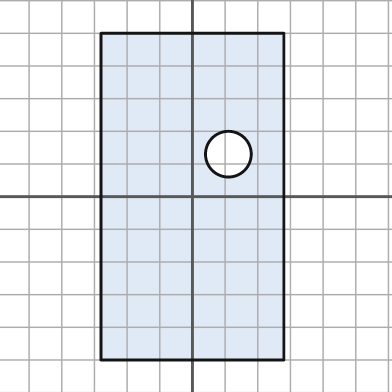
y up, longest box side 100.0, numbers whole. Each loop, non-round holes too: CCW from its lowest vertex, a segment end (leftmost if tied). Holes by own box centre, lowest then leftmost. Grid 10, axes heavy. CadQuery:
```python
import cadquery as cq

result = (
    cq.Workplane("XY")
    .moveTo(-28.0, -50.0)
    .lineTo(28.0, -50.0)
    .lineTo(28.0, 50.0)
    .lineTo(-28.0, 50.0)
    .close()
    .moveTo(11.0, 13.0)
    .circle(7.0)
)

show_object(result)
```